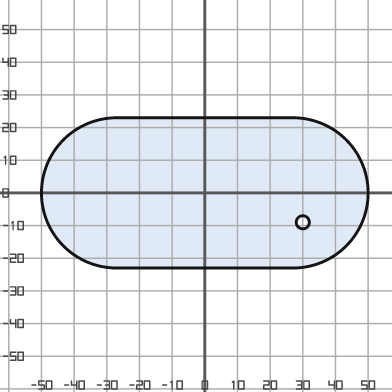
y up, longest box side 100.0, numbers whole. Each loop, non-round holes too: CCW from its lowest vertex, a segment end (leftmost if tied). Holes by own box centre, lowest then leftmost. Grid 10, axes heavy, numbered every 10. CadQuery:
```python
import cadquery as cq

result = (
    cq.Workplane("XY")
    .moveTo(-27.0, -23.0)
    .lineTo(27.0, -23.0)
    .threePointArc((50.0, 0.0), (27.0, 23.0))
    .lineTo(-27.0, 23.0)
    .threePointArc((-50.0, 0.0), (-27.0, -23.0))
    .close()
    .moveTo(30.0, -9.0)
    .circle(2.0)
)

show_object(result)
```